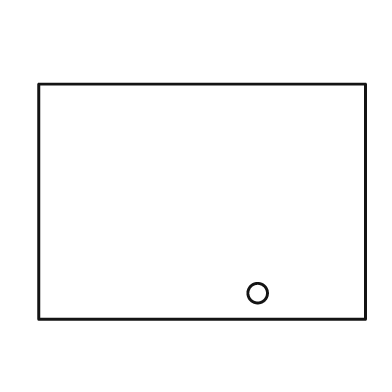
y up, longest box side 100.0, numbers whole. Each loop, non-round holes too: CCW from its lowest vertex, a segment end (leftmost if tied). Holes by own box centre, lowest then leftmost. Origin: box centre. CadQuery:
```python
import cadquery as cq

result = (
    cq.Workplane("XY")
    .moveTo(-50.0, -36.0)
    .lineTo(50.0, -36.0)
    .lineTo(50.0, 36.0)
    .lineTo(-50.0, 36.0)
    .close()
    .moveTo(17.0, -28.0)
    .circle(3.0)
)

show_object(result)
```